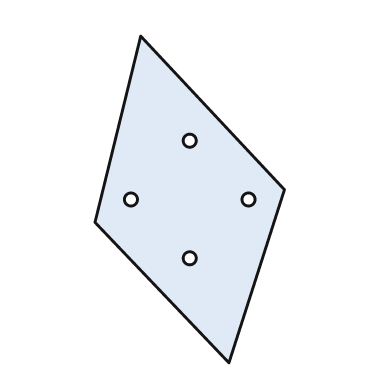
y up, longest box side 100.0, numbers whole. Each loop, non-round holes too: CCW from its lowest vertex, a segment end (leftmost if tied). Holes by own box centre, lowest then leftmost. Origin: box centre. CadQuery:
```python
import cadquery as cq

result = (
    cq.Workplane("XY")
    .moveTo(12.0, -50.0)
    .lineTo(29.0, 3.0)
    .lineTo(-15.0, 50.0)
    .lineTo(-29.0, -7.0)
    .close()
    .moveTo(0.0, -18.0)
    .circle(2.0)
    .moveTo(-18.0, 0.0)
    .circle(2.0)
    .moveTo(18.0, 0.0)
    .circle(2.0)
    .moveTo(0.0, 18.0)
    .circle(2.0)
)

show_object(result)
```